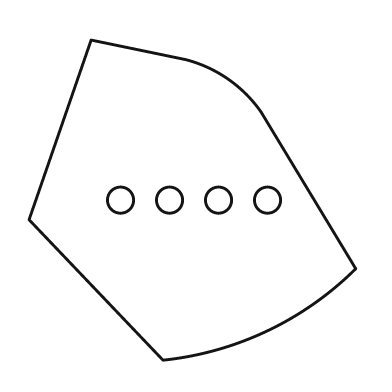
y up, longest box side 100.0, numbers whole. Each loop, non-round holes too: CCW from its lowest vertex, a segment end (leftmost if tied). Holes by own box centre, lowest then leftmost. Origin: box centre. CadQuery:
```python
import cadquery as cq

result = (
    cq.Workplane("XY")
    .moveTo(-9.0, -49.0)
    .threePointArc((23.0, -40.0), (50.0, -21.0))
    .lineTo(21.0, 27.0)
    .threePointArc((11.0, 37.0), (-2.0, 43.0))
    .lineTo(-31.0, 49.0)
    .lineTo(-50.0, -6.0)
    .close()
    .moveTo(-22.0, 0.0)
    .circle(4.0)
    .moveTo(-7.0, 0.0)
    .circle(4.0)
    .moveTo(8.0, 0.0)
    .circle(4.0)
    .moveTo(23.0, 0.0)
    .circle(4.0)
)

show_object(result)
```